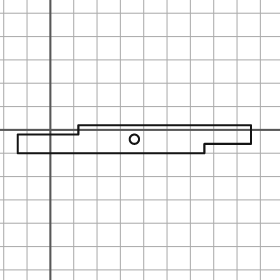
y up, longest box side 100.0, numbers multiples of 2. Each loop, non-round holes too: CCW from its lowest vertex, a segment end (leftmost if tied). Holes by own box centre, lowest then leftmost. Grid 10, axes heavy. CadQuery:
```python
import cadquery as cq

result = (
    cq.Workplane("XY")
    .moveTo(-14.0, -10.0)
    .lineTo(66.0, -10.0)
    .lineTo(66.0, -6.0)
    .lineTo(86.0, -6.0)
    .lineTo(86.0, 2.0)
    .lineTo(12.0, 2.0)
    .lineTo(12.0, -2.0)
    .lineTo(-14.0, -2.0)
    .close()
    .moveTo(36.0, -4.0)
    .circle(2.0)
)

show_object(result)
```